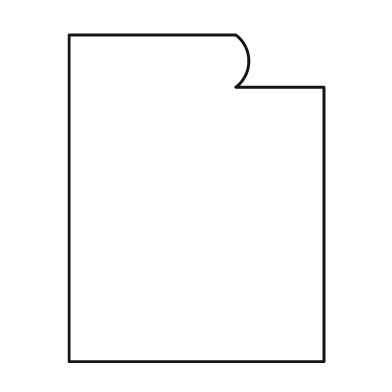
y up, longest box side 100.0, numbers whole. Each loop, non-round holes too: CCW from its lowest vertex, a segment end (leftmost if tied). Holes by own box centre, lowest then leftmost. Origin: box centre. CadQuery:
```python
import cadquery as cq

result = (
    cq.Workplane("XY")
    .moveTo(-39.0, -50.0)
    .lineTo(39.0, -50.0)
    .lineTo(39.0, 34.0)
    .lineTo(12.0, 34.0)
    .threePointArc((16.0, 42.0), (12.0, 50.0))
    .lineTo(-39.0, 50.0)
    .close()
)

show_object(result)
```